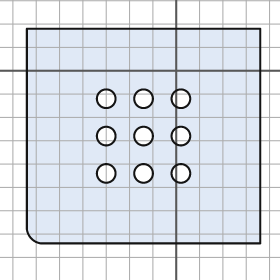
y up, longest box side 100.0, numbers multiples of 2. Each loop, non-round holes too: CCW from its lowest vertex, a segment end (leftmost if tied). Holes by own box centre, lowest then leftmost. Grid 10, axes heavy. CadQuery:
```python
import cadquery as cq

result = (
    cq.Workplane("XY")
    .moveTo(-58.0, -74.0)
    .lineTo(36.0, -74.0)
    .lineTo(36.0, 18.0)
    .lineTo(-64.0, 18.0)
    .lineTo(-64.0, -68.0)
    .threePointArc((-62.0, -72.0), (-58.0, -74.0))
    .close()
    .moveTo(-30.0, -44.0)
    .circle(4.0)
    .moveTo(-14.0, -44.0)
    .circle(4.0)
    .moveTo(2.0, -44.0)
    .circle(4.0)
    .moveTo(-30.0, -28.0)
    .circle(4.0)
    .moveTo(-14.0, -28.0)
    .circle(4.0)
    .moveTo(2.0, -28.0)
    .circle(4.0)
    .moveTo(-30.0, -12.0)
    .circle(4.0)
    .moveTo(-14.0, -12.0)
    .circle(4.0)
    .moveTo(2.0, -12.0)
    .circle(4.0)
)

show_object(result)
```